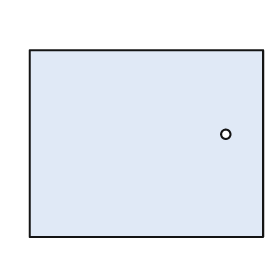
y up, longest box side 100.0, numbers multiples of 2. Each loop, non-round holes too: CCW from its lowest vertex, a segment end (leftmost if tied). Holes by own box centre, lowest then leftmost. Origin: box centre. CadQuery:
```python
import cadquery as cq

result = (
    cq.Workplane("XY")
    .moveTo(-50.0, -40.0)
    .lineTo(50.0, -40.0)
    .lineTo(50.0, 40.0)
    .lineTo(-50.0, 40.0)
    .close()
    .moveTo(34.0, 4.0)
    .circle(2.0)
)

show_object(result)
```